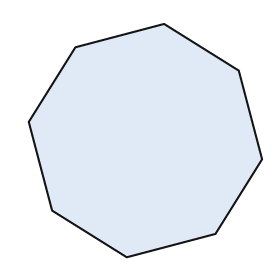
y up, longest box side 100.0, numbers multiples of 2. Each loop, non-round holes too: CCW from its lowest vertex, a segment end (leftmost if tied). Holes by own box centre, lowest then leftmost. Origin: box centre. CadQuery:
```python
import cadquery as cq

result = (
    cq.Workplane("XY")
    .moveTo(-8.0, -50.0)
    .lineTo(30.0, -40.0)
    .lineTo(50.0, -8.0)
    .lineTo(40.0, 30.0)
    .lineTo(8.0, 50.0)
    .lineTo(-30.0, 40.0)
    .lineTo(-50.0, 8.0)
    .lineTo(-40.0, -30.0)
    .close()
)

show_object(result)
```